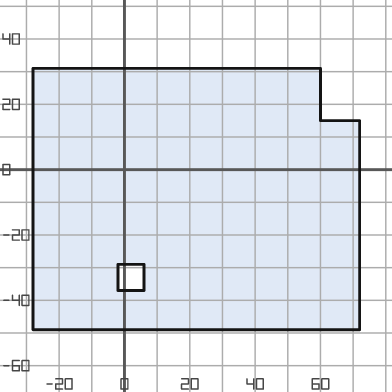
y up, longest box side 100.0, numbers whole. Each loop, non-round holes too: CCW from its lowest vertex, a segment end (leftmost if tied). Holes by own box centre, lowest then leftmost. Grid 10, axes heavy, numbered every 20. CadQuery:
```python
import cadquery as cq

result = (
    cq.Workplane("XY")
    .moveTo(-28.0, -49.0)
    .lineTo(72.0, -49.0)
    .lineTo(72.0, 15.0)
    .lineTo(60.0, 15.0)
    .lineTo(60.0, 31.0)
    .lineTo(-28.0, 31.0)
    .close()
    .moveTo(-2.0, -37.0)
    .lineTo(6.0, -37.0)
    .lineTo(6.0, -29.0)
    .lineTo(-2.0, -29.0)
    .close()
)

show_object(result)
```